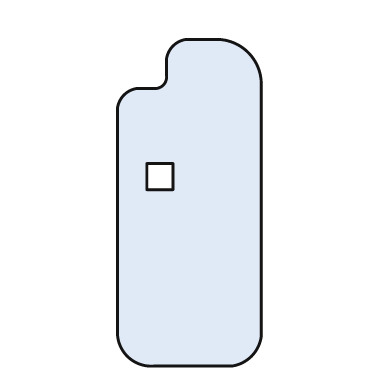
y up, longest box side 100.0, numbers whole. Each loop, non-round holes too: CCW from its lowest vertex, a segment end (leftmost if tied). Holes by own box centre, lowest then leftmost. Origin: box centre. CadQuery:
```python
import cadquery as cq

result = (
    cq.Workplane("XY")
    .moveTo(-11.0, -50.0)
    .lineTo(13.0, -50.0)
    .threePointArc((19.0, -47.0), (22.0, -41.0))
    .lineTo(22.0, 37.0)
    .threePointArc((18.0, 46.0), (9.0, 50.0))
    .lineTo(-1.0, 50.0)
    .threePointArc((-5.0, 48.0), (-7.0, 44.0))
    .lineTo(-7.0, 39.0)
    .threePointArc((-8.0, 36.0), (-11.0, 35.0))
    .lineTo(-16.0, 35.0)
    .threePointArc((-20.0, 33.0), (-22.0, 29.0))
    .lineTo(-22.0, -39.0)
    .threePointArc((-19.0, -47.0), (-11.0, -50.0))
    .close()
    .moveTo(-13.0, 4.0)
    .lineTo(-5.0, 4.0)
    .lineTo(-5.0, 12.0)
    .lineTo(-13.0, 12.0)
    .close()
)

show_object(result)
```